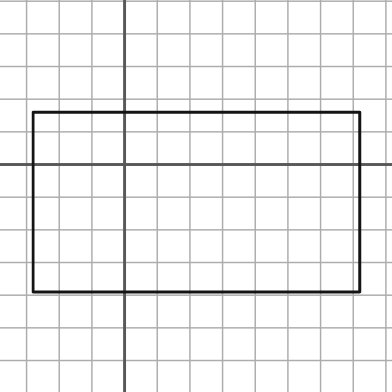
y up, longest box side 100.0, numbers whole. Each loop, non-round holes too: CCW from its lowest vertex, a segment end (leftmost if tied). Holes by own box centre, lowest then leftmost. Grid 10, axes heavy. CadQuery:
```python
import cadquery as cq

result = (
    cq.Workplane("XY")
    .moveTo(-28.0, -39.0)
    .lineTo(72.0, -39.0)
    .lineTo(72.0, 16.0)
    .lineTo(-28.0, 16.0)
    .close()
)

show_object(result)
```